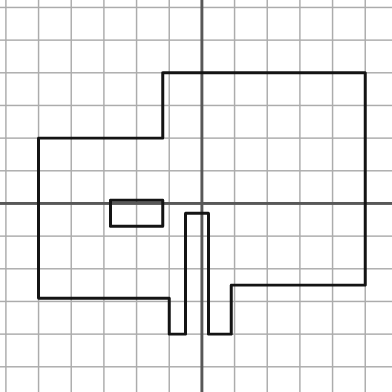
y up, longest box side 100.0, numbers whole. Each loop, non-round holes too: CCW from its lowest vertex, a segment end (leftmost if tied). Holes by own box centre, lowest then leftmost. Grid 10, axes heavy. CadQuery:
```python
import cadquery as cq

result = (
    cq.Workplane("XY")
    .moveTo(-10.0, -40.0)
    .lineTo(-5.0, -40.0)
    .lineTo(-5.0, -3.0)
    .lineTo(2.0, -3.0)
    .lineTo(2.0, -40.0)
    .lineTo(9.0, -40.0)
    .lineTo(9.0, -25.0)
    .lineTo(50.0, -25.0)
    .lineTo(50.0, 40.0)
    .lineTo(-12.0, 40.0)
    .lineTo(-12.0, 20.0)
    .lineTo(-50.0, 20.0)
    .lineTo(-50.0, -29.0)
    .lineTo(-10.0, -29.0)
    .close()
    .moveTo(-28.0, -7.0)
    .lineTo(-12.0, -7.0)
    .lineTo(-12.0, 1.0)
    .lineTo(-28.0, 1.0)
    .close()
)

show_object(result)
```